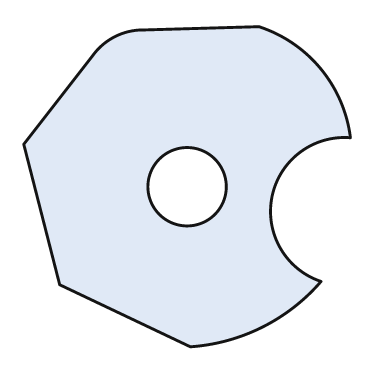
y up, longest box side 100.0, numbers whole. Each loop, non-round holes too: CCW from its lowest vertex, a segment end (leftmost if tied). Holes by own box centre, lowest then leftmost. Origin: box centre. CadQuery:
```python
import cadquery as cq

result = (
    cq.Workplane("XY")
    .moveTo(1.0, -49.0)
    .threePointArc((23.0, -43.0), (41.0, -29.0))
    .threePointArc((26.0, -3.0), (50.0, 15.0))
    .threePointArc((41.0, 36.0), (22.0, 49.0))
    .lineTo(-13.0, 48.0)
    .threePointArc((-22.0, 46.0), (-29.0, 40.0))
    .lineTo(-50.0, 13.0)
    .lineTo(-39.0, -30.0)
    .close()
    .moveTo(0.0, 0.0)
    .circle(12.0)
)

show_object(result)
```